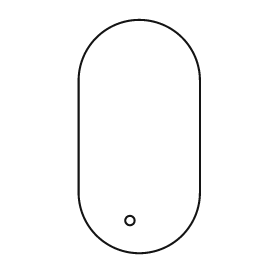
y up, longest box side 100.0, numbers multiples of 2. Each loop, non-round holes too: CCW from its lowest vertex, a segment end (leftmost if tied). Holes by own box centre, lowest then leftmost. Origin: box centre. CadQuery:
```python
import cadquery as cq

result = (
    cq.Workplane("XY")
    .moveTo(-26.0, -24.0)
    .threePointArc((0.0, -50.0), (26.0, -24.0))
    .lineTo(26.0, 24.0)
    .threePointArc((0.0, 50.0), (-26.0, 24.0))
    .close()
    .moveTo(-4.0, -36.0)
    .circle(2.0)
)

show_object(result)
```